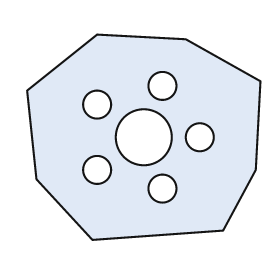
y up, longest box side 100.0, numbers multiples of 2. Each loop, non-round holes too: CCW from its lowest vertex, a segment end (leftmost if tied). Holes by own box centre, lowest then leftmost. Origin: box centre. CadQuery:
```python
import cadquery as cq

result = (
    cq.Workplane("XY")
    .moveTo(-22.0, -44.0)
    .lineTo(34.0, -40.0)
    .lineTo(48.0, -14.0)
    .lineTo(50.0, 24.0)
    .lineTo(18.0, 42.0)
    .lineTo(-20.0, 44.0)
    .lineTo(-50.0, 20.0)
    .lineTo(-46.0, -18.0)
    .close()
    .moveTo(8.0, -22.0)
    .circle(6.0)
    .moveTo(-20.0, -14.0)
    .circle(6.0)
    .moveTo(0.0, 0.0)
    .circle(12.0)
    .moveTo(24.0, 0.0)
    .circle(6.0)
    .moveTo(-20.0, 14.0)
    .circle(6.0)
    .moveTo(8.0, 22.0)
    .circle(6.0)
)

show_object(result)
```